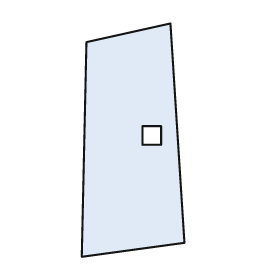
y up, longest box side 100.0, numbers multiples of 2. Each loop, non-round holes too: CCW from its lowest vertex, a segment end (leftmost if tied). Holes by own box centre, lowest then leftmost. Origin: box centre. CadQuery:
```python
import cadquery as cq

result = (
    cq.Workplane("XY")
    .moveTo(-22.0, -50.0)
    .lineTo(22.0, -44.0)
    .lineTo(16.0, 50.0)
    .lineTo(-20.0, 42.0)
    .close()
    .moveTo(4.0, -2.0)
    .lineTo(12.0, -2.0)
    .lineTo(12.0, 6.0)
    .lineTo(4.0, 6.0)
    .close()
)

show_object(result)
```